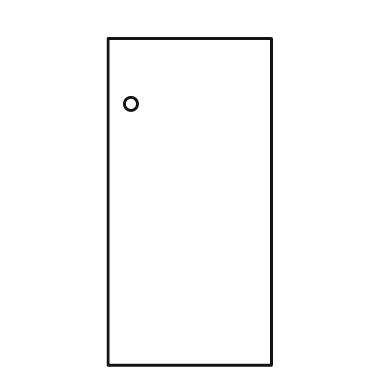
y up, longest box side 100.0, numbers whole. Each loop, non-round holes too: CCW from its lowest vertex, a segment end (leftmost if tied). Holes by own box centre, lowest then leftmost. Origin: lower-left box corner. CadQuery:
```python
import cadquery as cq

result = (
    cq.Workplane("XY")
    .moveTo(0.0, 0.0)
    .lineTo(50.0, 0.0)
    .lineTo(50.0, 100.0)
    .lineTo(0.0, 100.0)
    .close()
    .moveTo(7.0, 80.0)
    .circle(2.0)
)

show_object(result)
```